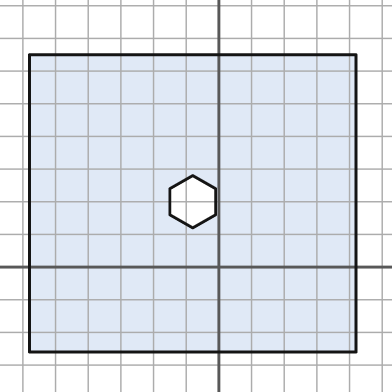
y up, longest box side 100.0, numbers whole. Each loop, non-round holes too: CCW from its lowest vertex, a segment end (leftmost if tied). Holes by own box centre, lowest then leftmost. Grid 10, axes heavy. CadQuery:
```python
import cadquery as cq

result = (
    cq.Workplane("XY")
    .moveTo(-58.0, -26.0)
    .lineTo(42.0, -26.0)
    .lineTo(42.0, 65.0)
    .lineTo(-58.0, 65.0)
    .close()
    .moveTo(-8.0, 12.0)
    .lineTo(-1.0, 16.0)
    .lineTo(-1.0, 24.0)
    .lineTo(-8.0, 28.0)
    .lineTo(-15.0, 24.0)
    .lineTo(-15.0, 16.0)
    .close()
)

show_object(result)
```